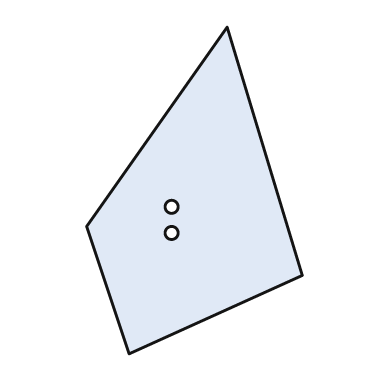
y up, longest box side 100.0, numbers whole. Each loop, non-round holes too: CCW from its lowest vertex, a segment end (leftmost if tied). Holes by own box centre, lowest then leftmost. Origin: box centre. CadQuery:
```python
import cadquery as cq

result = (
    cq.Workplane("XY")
    .moveTo(-20.0, -50.0)
    .lineTo(33.0, -26.0)
    .lineTo(10.0, 50.0)
    .lineTo(-33.0, -11.0)
    .close()
    .moveTo(-7.0, -13.0)
    .circle(2.0)
    .moveTo(-7.0, -5.0)
    .circle(2.0)
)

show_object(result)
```